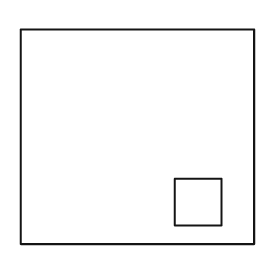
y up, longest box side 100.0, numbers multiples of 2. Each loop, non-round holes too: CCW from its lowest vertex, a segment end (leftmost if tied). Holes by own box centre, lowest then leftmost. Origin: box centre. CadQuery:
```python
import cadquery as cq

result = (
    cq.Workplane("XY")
    .moveTo(-50.0, -46.0)
    .lineTo(50.0, -46.0)
    .lineTo(50.0, 46.0)
    .lineTo(-50.0, 46.0)
    .close()
    .moveTo(16.0, -38.0)
    .lineTo(36.0, -38.0)
    .lineTo(36.0, -18.0)
    .lineTo(16.0, -18.0)
    .close()
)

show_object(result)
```